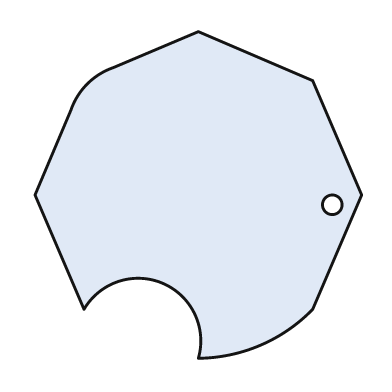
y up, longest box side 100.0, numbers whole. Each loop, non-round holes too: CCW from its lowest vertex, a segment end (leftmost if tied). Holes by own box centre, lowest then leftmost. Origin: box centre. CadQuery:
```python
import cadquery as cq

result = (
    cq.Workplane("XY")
    .moveTo(0.0, -50.0)
    .threePointArc((19.0, -46.0), (35.0, -35.0))
    .lineTo(50.0, 0.0)
    .lineTo(35.0, 35.0)
    .lineTo(0.0, 50.0)
    .lineTo(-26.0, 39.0)
    .threePointArc((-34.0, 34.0), (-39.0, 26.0))
    .lineTo(-50.0, 0.0)
    .lineTo(-35.0, -35.0)
    .threePointArc((-11.0, -27.0), (0.0, -50.0))
    .close()
    .moveTo(41.0, -3.0)
    .circle(3.0)
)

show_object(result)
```